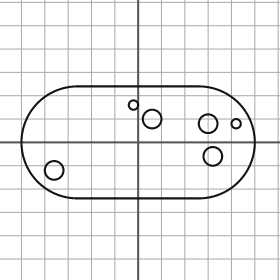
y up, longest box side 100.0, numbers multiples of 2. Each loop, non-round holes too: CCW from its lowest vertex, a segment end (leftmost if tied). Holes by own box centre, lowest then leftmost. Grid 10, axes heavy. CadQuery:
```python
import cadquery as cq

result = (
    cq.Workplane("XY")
    .moveTo(-26.0, -24.0)
    .lineTo(26.0, -24.0)
    .threePointArc((50.0, 0.0), (26.0, 24.0))
    .lineTo(-26.0, 24.0)
    .threePointArc((-50.0, 0.0), (-26.0, -24.0))
    .close()
    .moveTo(-36.0, -12.0)
    .circle(4.0)
    .moveTo(32.0, -6.0)
    .circle(4.0)
    .moveTo(30.0, 8.0)
    .circle(4.0)
    .moveTo(42.0, 8.0)
    .circle(2.0)
    .moveTo(6.0, 10.0)
    .circle(4.0)
    .moveTo(-2.0, 16.0)
    .circle(2.0)
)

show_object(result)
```